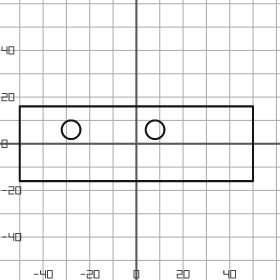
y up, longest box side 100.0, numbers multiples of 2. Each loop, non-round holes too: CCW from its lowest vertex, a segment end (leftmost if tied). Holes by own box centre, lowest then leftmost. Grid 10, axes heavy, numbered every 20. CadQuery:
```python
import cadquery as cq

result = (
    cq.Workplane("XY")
    .moveTo(-50.0, -16.0)
    .lineTo(50.0, -16.0)
    .lineTo(50.0, 16.0)
    .lineTo(-50.0, 16.0)
    .close()
    .moveTo(-28.0, 6.0)
    .circle(4.0)
    .moveTo(8.0, 6.0)
    .circle(4.0)
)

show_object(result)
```